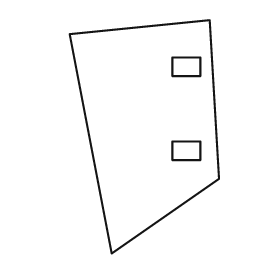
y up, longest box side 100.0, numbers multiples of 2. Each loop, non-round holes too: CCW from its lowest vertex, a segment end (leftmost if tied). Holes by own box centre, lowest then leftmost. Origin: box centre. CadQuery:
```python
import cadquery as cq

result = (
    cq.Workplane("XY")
    .moveTo(-14.0, -50.0)
    .lineTo(32.0, -18.0)
    .lineTo(28.0, 50.0)
    .lineTo(-32.0, 44.0)
    .close()
    .moveTo(12.0, -10.0)
    .lineTo(24.0, -10.0)
    .lineTo(24.0, -2.0)
    .lineTo(12.0, -2.0)
    .close()
    .moveTo(12.0, 26.0)
    .lineTo(24.0, 26.0)
    .lineTo(24.0, 34.0)
    .lineTo(12.0, 34.0)
    .close()
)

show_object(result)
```